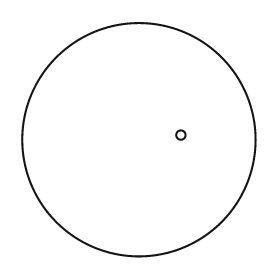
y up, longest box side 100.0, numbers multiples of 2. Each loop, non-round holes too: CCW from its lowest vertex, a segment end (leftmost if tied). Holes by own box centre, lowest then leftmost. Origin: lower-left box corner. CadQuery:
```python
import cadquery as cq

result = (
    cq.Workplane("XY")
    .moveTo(50.0, 50.0)
    .circle(50.0)
    .moveTo(68.0, 52.0)
    .circle(2.0)
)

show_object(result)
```